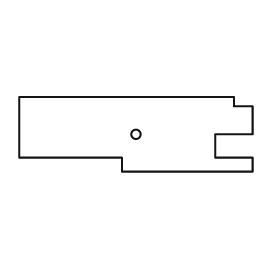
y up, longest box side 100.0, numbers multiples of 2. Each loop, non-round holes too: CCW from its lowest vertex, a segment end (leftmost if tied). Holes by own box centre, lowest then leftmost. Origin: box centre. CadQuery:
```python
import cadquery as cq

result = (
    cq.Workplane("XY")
    .moveTo(-6.0, -16.0)
    .lineTo(50.0, -16.0)
    .lineTo(50.0, -10.0)
    .lineTo(34.0, -10.0)
    .lineTo(34.0, 0.0)
    .lineTo(50.0, 0.0)
    .lineTo(50.0, 12.0)
    .lineTo(42.0, 12.0)
    .lineTo(42.0, 16.0)
    .lineTo(-50.0, 16.0)
    .lineTo(-50.0, -10.0)
    .lineTo(-6.0, -10.0)
    .close()
    .moveTo(0.0, 0.0)
    .circle(2.0)
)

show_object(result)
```